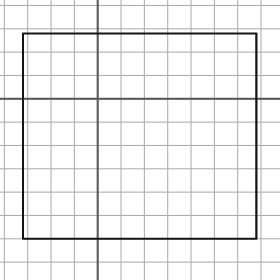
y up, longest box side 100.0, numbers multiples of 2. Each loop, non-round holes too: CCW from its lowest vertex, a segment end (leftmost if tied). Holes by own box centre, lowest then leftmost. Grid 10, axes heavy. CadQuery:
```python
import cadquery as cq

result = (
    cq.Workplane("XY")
    .moveTo(-32.0, -60.0)
    .lineTo(68.0, -60.0)
    .lineTo(68.0, 28.0)
    .lineTo(-32.0, 28.0)
    .close()
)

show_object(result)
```